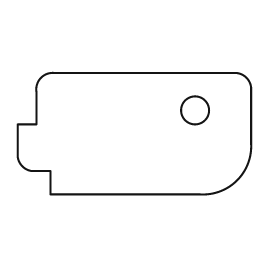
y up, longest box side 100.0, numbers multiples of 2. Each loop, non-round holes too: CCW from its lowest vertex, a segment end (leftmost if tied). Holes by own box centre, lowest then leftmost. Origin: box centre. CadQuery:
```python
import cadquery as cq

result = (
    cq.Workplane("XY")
    .moveTo(-36.0, -26.0)
    .lineTo(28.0, -26.0)
    .threePointArc((44.0, -20.0), (50.0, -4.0))
    .lineTo(50.0, 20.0)
    .threePointArc((48.0, 24.0), (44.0, 26.0))
    .lineTo(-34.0, 26.0)
    .threePointArc((-40.0, 24.0), (-42.0, 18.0))
    .lineTo(-42.0, 4.0)
    .lineTo(-50.0, 4.0)
    .lineTo(-50.0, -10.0)
    .threePointArc((-48.0, -14.0), (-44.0, -16.0))
    .lineTo(-36.0, -16.0)
    .close()
    .moveTo(26.0, 10.0)
    .circle(6.0)
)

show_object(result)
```